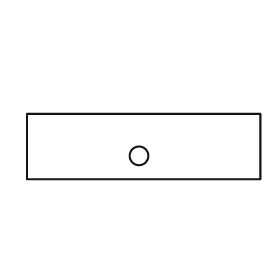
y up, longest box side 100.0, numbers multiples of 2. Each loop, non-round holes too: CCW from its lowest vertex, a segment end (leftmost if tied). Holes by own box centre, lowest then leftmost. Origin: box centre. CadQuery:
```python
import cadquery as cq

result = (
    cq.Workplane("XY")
    .moveTo(-50.0, -14.0)
    .lineTo(50.0, -14.0)
    .lineTo(50.0, 14.0)
    .lineTo(-50.0, 14.0)
    .close()
    .moveTo(-2.0, -4.0)
    .circle(4.0)
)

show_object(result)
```